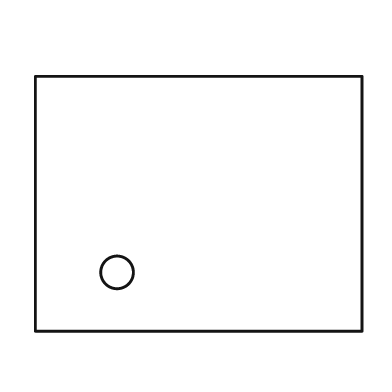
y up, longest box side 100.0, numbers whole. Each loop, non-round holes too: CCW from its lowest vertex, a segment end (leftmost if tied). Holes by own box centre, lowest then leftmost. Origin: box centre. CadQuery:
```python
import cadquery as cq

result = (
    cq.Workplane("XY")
    .moveTo(-50.0, -39.0)
    .lineTo(50.0, -39.0)
    .lineTo(50.0, 39.0)
    .lineTo(-50.0, 39.0)
    .close()
    .moveTo(-25.0, -21.0)
    .circle(5.0)
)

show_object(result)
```